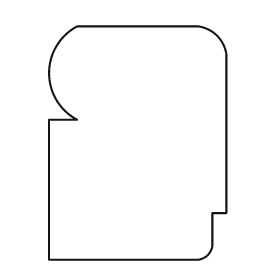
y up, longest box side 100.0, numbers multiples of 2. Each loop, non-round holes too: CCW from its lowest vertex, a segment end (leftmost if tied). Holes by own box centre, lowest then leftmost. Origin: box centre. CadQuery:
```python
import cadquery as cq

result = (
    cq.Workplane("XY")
    .moveTo(-38.0, -50.0)
    .lineTo(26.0, -50.0)
    .threePointArc((30.0, -48.0), (32.0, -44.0))
    .lineTo(32.0, -30.0)
    .lineTo(38.0, -30.0)
    .lineTo(38.0, 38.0)
    .threePointArc((34.0, 46.0), (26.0, 50.0))
    .lineTo(-26.0, 50.0)
    .threePointArc((-38.0, 30.0), (-26.0, 10.0))
    .lineTo(-38.0, 10.0)
    .close()
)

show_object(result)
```